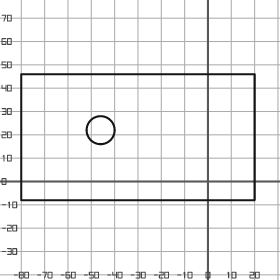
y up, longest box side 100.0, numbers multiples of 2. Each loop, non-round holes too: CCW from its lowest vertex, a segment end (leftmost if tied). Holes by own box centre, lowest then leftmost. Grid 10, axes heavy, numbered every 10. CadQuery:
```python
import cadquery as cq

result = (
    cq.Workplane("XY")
    .moveTo(-80.0, -8.0)
    .lineTo(20.0, -8.0)
    .lineTo(20.0, 46.0)
    .lineTo(-80.0, 46.0)
    .close()
    .moveTo(-46.0, 22.0)
    .circle(6.0)
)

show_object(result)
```